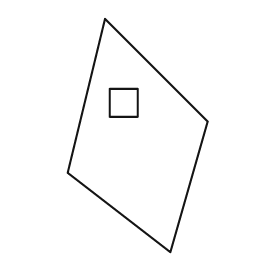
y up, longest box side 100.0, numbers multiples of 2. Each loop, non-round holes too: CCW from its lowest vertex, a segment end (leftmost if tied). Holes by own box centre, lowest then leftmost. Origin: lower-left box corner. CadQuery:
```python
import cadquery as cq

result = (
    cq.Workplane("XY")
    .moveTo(44.0, 0.0)
    .lineTo(60.0, 56.0)
    .lineTo(16.0, 100.0)
    .lineTo(0.0, 34.0)
    .close()
    .moveTo(18.0, 58.0)
    .lineTo(30.0, 58.0)
    .lineTo(30.0, 70.0)
    .lineTo(18.0, 70.0)
    .close()
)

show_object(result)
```